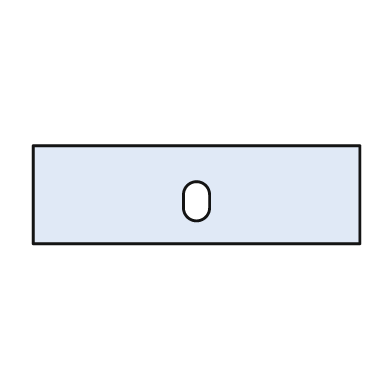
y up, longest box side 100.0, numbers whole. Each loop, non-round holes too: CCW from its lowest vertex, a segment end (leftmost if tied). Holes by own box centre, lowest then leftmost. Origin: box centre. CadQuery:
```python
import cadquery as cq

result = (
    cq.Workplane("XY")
    .moveTo(-50.0, -15.0)
    .lineTo(50.0, -15.0)
    .lineTo(50.0, 15.0)
    .lineTo(-50.0, 15.0)
    .close()
    .moveTo(-4.0, -4.0)
    .threePointArc((0.0, -8.0), (4.0, -4.0))
    .lineTo(4.0, 0.0)
    .threePointArc((0.0, 4.0), (-4.0, 0.0))
    .close()
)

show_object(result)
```